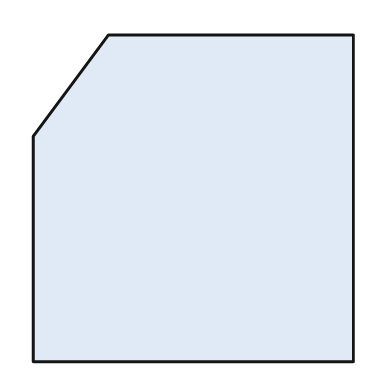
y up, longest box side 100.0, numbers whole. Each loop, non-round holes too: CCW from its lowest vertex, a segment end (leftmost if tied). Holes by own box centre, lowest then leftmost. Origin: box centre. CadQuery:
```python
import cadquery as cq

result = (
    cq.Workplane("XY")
    .moveTo(-49.0, -50.0)
    .lineTo(49.0, -50.0)
    .lineTo(49.0, 50.0)
    .lineTo(-26.0, 50.0)
    .lineTo(-49.0, 19.0)
    .close()
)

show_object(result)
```